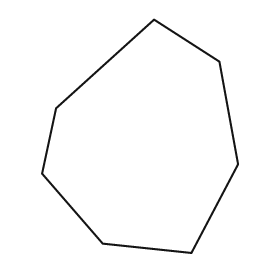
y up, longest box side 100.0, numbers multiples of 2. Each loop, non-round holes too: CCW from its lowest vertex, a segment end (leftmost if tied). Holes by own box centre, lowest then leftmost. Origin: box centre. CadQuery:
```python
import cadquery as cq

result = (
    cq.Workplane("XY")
    .moveTo(22.0, -50.0)
    .lineTo(42.0, -12.0)
    .lineTo(34.0, 32.0)
    .lineTo(6.0, 50.0)
    .lineTo(-36.0, 12.0)
    .lineTo(-42.0, -16.0)
    .lineTo(-16.0, -46.0)
    .close()
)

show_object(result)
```